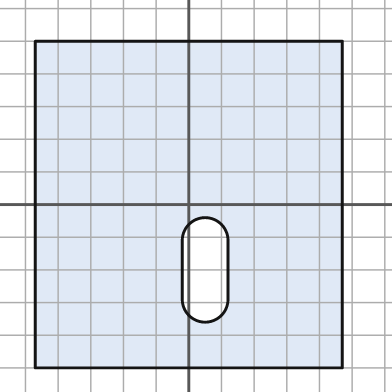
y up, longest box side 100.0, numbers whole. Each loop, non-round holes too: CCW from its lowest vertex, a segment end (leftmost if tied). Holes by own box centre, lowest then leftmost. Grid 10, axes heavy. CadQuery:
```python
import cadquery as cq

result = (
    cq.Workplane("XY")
    .moveTo(-47.0, -50.0)
    .lineTo(47.0, -50.0)
    .lineTo(47.0, 50.0)
    .lineTo(-47.0, 50.0)
    .close()
    .moveTo(-2.0, -29.0)
    .threePointArc((5.0, -36.0), (12.0, -29.0))
    .lineTo(12.0, -11.0)
    .threePointArc((5.0, -4.0), (-2.0, -11.0))
    .close()
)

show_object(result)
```